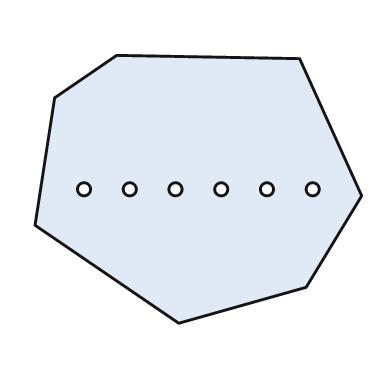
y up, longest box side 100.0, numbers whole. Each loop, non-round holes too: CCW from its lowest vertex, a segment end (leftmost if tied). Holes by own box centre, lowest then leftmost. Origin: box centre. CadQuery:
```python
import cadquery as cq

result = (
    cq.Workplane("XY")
    .moveTo(-6.0, -41.0)
    .lineTo(33.0, -30.0)
    .lineTo(50.0, -2.0)
    .lineTo(31.0, 40.0)
    .lineTo(-25.0, 41.0)
    .lineTo(-44.0, 28.0)
    .lineTo(-50.0, -11.0)
    .close()
    .moveTo(-35.0, 0.0)
    .circle(2.0)
    .moveTo(-21.0, 0.0)
    .circle(2.0)
    .moveTo(-7.0, 0.0)
    .circle(2.0)
    .moveTo(7.0, 0.0)
    .circle(2.0)
    .moveTo(21.0, 0.0)
    .circle(2.0)
    .moveTo(35.0, 0.0)
    .circle(2.0)
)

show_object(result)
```